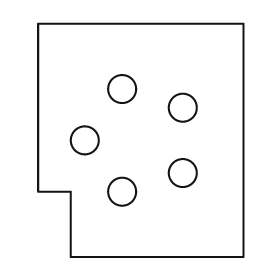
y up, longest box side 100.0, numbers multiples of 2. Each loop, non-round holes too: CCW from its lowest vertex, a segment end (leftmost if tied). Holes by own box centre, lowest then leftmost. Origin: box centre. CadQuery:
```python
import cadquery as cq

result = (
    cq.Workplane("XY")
    .moveTo(-30.0, -50.0)
    .lineTo(44.0, -50.0)
    .lineTo(44.0, 50.0)
    .lineTo(-44.0, 50.0)
    .lineTo(-44.0, -22.0)
    .lineTo(-30.0, -22.0)
    .close()
    .moveTo(-8.0, -22.0)
    .circle(6.0)
    .moveTo(18.0, -14.0)
    .circle(6.0)
    .moveTo(-24.0, 0.0)
    .circle(6.0)
    .moveTo(18.0, 14.0)
    .circle(6.0)
    .moveTo(-8.0, 22.0)
    .circle(6.0)
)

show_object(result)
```